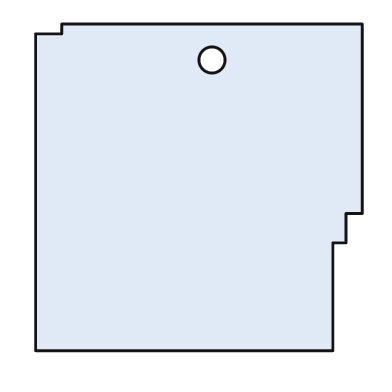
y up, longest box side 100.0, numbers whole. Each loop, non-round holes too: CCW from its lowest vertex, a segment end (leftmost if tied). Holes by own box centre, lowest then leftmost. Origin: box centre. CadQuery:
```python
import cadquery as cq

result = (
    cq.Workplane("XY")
    .moveTo(-50.0, -50.0)
    .lineTo(41.0, -50.0)
    .lineTo(41.0, -17.0)
    .lineTo(45.0, -17.0)
    .lineTo(45.0, -8.0)
    .lineTo(50.0, -8.0)
    .lineTo(50.0, 50.0)
    .lineTo(-42.0, 50.0)
    .lineTo(-42.0, 47.0)
    .lineTo(-50.0, 47.0)
    .close()
    .moveTo(4.0, 39.0)
    .circle(4.0)
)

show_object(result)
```